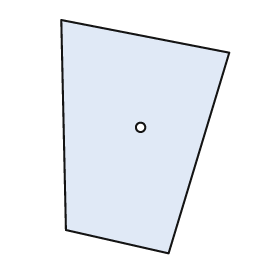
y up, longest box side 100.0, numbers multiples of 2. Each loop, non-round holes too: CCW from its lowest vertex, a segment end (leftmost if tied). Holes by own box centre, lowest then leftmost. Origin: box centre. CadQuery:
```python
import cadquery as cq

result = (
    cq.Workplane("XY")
    .moveTo(10.0, -50.0)
    .lineTo(36.0, 36.0)
    .lineTo(-36.0, 50.0)
    .lineTo(-34.0, -40.0)
    .close()
    .moveTo(-2.0, 4.0)
    .circle(2.0)
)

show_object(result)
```